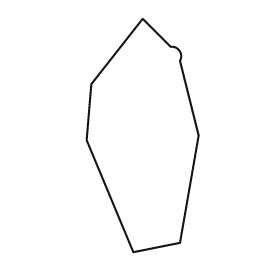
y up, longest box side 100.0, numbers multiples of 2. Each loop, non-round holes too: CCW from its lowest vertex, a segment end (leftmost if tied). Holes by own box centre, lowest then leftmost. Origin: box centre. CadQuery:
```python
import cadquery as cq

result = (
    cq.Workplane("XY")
    .moveTo(-4.0, -50.0)
    .lineTo(16.0, -46.0)
    .lineTo(24.0, 0.0)
    .lineTo(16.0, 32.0)
    .threePointArc((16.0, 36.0), (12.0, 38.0))
    .lineTo(0.0, 50.0)
    .lineTo(-22.0, 22.0)
    .lineTo(-24.0, -2.0)
    .close()
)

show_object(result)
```